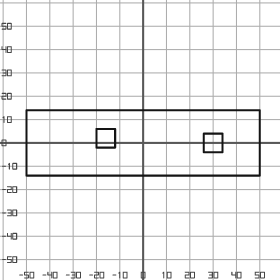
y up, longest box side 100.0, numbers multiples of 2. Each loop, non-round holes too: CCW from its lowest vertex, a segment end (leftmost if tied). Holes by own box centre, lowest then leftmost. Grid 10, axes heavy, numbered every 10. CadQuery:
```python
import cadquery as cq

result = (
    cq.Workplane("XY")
    .moveTo(-50.0, -14.0)
    .lineTo(50.0, -14.0)
    .lineTo(50.0, 14.0)
    .lineTo(-50.0, 14.0)
    .close()
    .moveTo(26.0, -4.0)
    .lineTo(34.0, -4.0)
    .lineTo(34.0, 4.0)
    .lineTo(26.0, 4.0)
    .close()
    .moveTo(-20.0, -2.0)
    .lineTo(-12.0, -2.0)
    .lineTo(-12.0, 6.0)
    .lineTo(-20.0, 6.0)
    .close()
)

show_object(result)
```